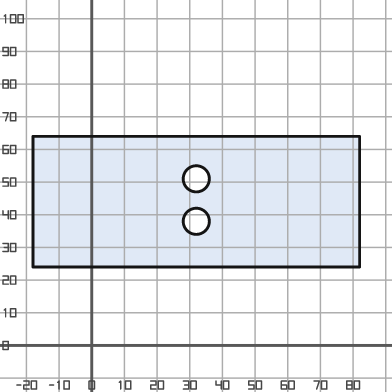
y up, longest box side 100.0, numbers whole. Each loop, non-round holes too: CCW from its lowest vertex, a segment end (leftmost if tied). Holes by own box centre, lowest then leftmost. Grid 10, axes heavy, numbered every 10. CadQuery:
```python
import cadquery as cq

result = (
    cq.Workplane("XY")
    .moveTo(-18.0, 24.0)
    .lineTo(82.0, 24.0)
    .lineTo(82.0, 64.0)
    .lineTo(-18.0, 64.0)
    .close()
    .moveTo(32.0, 38.0)
    .circle(4.0)
    .moveTo(32.0, 51.0)
    .circle(4.0)
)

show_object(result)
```